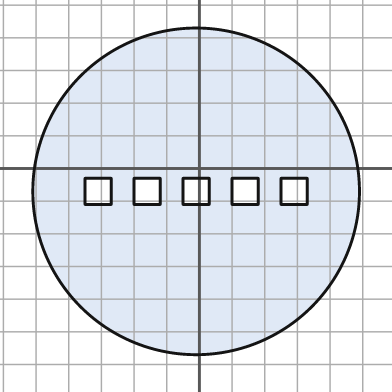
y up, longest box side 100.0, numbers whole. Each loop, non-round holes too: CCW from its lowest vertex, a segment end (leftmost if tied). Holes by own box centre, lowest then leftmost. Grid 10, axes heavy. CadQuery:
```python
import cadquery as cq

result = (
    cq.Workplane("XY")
    .moveTo(-1.0, -7.0)
    .circle(50.0)
    .moveTo(-35.0, -11.0)
    .lineTo(-27.0, -11.0)
    .lineTo(-27.0, -3.0)
    .lineTo(-35.0, -3.0)
    .close()
    .moveTo(-20.0, -11.0)
    .lineTo(-12.0, -11.0)
    .lineTo(-12.0, -3.0)
    .lineTo(-20.0, -3.0)
    .close()
    .moveTo(-5.0, -11.0)
    .lineTo(3.0, -11.0)
    .lineTo(3.0, -3.0)
    .lineTo(-5.0, -3.0)
    .close()
    .moveTo(10.0, -11.0)
    .lineTo(18.0, -11.0)
    .lineTo(18.0, -3.0)
    .lineTo(10.0, -3.0)
    .close()
    .moveTo(25.0, -11.0)
    .lineTo(33.0, -11.0)
    .lineTo(33.0, -3.0)
    .lineTo(25.0, -3.0)
    .close()
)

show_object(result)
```